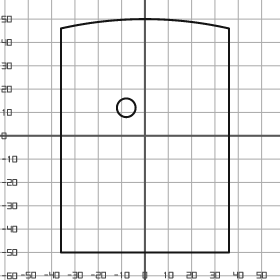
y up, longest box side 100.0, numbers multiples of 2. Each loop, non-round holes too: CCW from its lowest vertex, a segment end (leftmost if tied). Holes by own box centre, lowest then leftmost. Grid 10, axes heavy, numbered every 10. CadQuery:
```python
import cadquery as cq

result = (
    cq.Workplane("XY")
    .moveTo(-36.0, -50.0)
    .lineTo(36.0, -50.0)
    .lineTo(36.0, 46.0)
    .threePointArc((0.0, 50.0), (-36.0, 46.0))
    .close()
    .moveTo(-8.0, 12.0)
    .circle(4.0)
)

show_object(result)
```